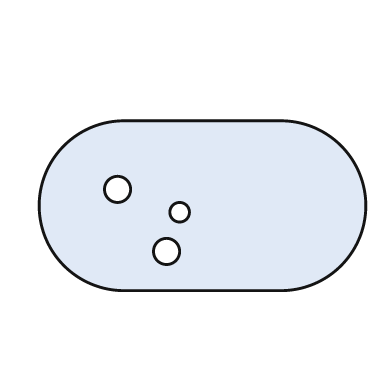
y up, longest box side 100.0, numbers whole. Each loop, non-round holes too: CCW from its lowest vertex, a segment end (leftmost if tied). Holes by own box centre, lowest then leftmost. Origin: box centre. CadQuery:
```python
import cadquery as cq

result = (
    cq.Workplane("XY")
    .moveTo(-24.0, -26.0)
    .lineTo(24.0, -26.0)
    .threePointArc((50.0, 0.0), (24.0, 26.0))
    .lineTo(-24.0, 26.0)
    .threePointArc((-50.0, 0.0), (-24.0, -26.0))
    .close()
    .moveTo(-11.0, -14.0)
    .circle(4.0)
    .moveTo(-7.0, -2.0)
    .circle(3.0)
    .moveTo(-26.0, 5.0)
    .circle(4.0)
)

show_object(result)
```